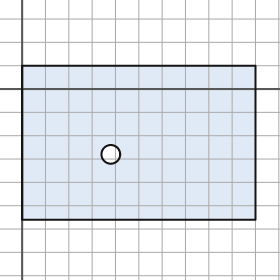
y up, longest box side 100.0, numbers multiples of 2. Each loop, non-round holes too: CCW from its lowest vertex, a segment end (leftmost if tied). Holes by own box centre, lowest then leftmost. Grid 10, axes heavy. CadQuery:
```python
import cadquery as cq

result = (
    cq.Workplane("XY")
    .moveTo(0.0, -56.0)
    .lineTo(100.0, -56.0)
    .lineTo(100.0, 10.0)
    .lineTo(0.0, 10.0)
    .close()
    .moveTo(38.0, -28.0)
    .circle(4.0)
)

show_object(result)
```